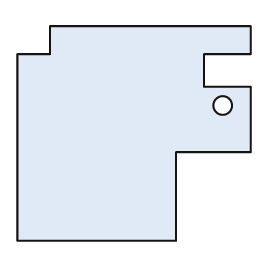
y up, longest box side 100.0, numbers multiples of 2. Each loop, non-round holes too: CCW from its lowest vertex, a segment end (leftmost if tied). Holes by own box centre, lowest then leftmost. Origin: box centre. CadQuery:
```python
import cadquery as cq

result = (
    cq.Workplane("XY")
    .moveTo(-50.0, -46.0)
    .lineTo(18.0, -46.0)
    .lineTo(18.0, -8.0)
    .lineTo(50.0, -8.0)
    .lineTo(50.0, 20.0)
    .lineTo(30.0, 20.0)
    .lineTo(30.0, 34.0)
    .lineTo(50.0, 34.0)
    .lineTo(50.0, 46.0)
    .lineTo(-36.0, 46.0)
    .lineTo(-36.0, 34.0)
    .lineTo(-50.0, 34.0)
    .close()
    .moveTo(38.0, 12.0)
    .circle(4.0)
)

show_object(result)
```